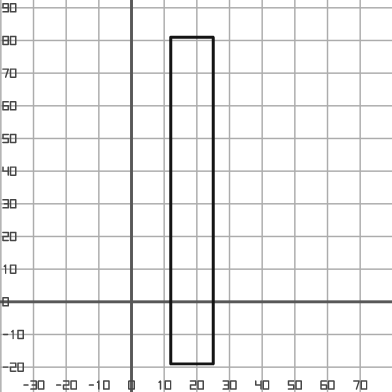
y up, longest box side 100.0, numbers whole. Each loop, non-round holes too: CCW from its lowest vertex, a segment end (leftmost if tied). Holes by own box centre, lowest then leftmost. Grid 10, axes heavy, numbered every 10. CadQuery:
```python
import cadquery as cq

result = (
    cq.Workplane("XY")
    .moveTo(12.0, -19.0)
    .lineTo(25.0, -19.0)
    .lineTo(25.0, 81.0)
    .lineTo(12.0, 81.0)
    .close()
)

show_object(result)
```